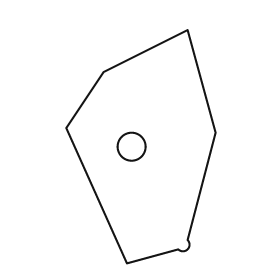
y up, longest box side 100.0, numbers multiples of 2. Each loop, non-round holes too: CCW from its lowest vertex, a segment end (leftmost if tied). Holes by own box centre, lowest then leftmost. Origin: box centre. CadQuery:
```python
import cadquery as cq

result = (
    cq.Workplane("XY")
    .moveTo(-6.0, -50.0)
    .lineTo(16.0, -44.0)
    .threePointArc((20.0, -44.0), (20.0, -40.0))
    .lineTo(32.0, 6.0)
    .lineTo(20.0, 50.0)
    .lineTo(-16.0, 32.0)
    .lineTo(-32.0, 8.0)
    .close()
    .moveTo(-4.0, 0.0)
    .circle(6.0)
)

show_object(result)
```